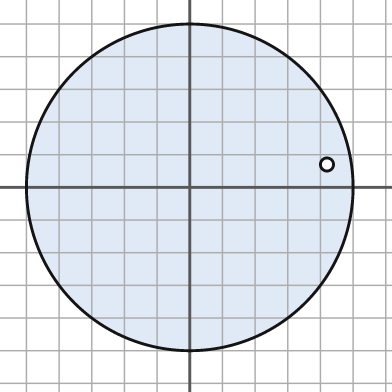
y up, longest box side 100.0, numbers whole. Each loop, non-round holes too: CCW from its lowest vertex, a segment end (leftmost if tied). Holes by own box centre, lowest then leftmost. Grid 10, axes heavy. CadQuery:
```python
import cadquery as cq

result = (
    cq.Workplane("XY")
    .moveTo(0.0, 0.0)
    .circle(50.0)
    .moveTo(42.0, 7.0)
    .circle(2.0)
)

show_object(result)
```